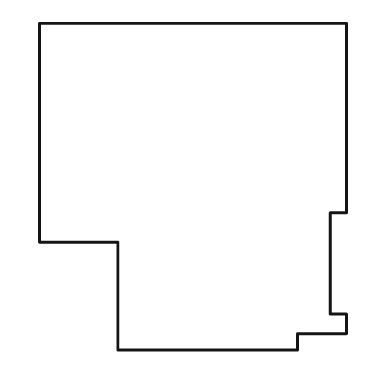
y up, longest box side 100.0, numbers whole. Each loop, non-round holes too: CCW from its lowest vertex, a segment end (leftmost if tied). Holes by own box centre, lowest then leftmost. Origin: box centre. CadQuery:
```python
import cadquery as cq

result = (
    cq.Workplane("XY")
    .moveTo(-23.0, -50.0)
    .lineTo(32.0, -50.0)
    .lineTo(32.0, -45.0)
    .lineTo(47.0, -45.0)
    .lineTo(47.0, -39.0)
    .lineTo(42.0, -39.0)
    .lineTo(42.0, -8.0)
    .lineTo(47.0, -8.0)
    .lineTo(47.0, 50.0)
    .lineTo(-47.0, 50.0)
    .lineTo(-47.0, -17.0)
    .lineTo(-23.0, -17.0)
    .close()
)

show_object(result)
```